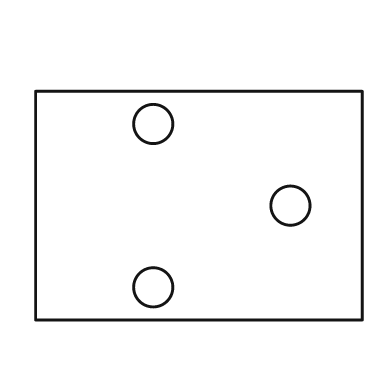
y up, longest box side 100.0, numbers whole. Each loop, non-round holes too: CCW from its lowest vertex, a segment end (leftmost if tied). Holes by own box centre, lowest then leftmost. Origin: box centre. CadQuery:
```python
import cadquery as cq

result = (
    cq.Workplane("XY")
    .moveTo(-50.0, -35.0)
    .lineTo(50.0, -35.0)
    .lineTo(50.0, 35.0)
    .lineTo(-50.0, 35.0)
    .close()
    .moveTo(-14.0, -25.0)
    .circle(6.0)
    .moveTo(28.0, 0.0)
    .circle(6.0)
    .moveTo(-14.0, 25.0)
    .circle(6.0)
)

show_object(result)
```